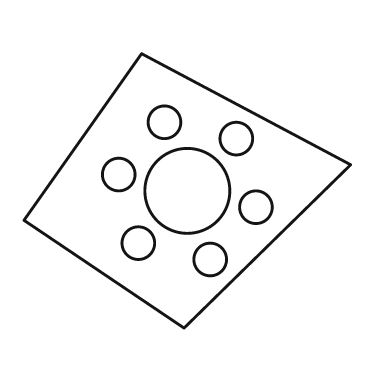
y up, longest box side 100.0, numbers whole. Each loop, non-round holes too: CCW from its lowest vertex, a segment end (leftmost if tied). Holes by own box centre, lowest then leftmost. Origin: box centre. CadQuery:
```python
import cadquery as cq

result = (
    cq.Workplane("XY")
    .moveTo(-1.0, -42.0)
    .lineTo(50.0, 8.0)
    .lineTo(-14.0, 42.0)
    .lineTo(-50.0, -9.0)
    .close()
    .moveTo(7.0, -21.0)
    .circle(5.0)
    .moveTo(-15.0, -16.0)
    .circle(5.0)
    .moveTo(21.0, -5.0)
    .circle(5.0)
    .moveTo(0.0, 0.0)
    .circle(13.0)
    .moveTo(-21.0, 5.0)
    .circle(5.0)
    .moveTo(15.0, 16.0)
    .circle(5.0)
    .moveTo(-7.0, 21.0)
    .circle(5.0)
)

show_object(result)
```